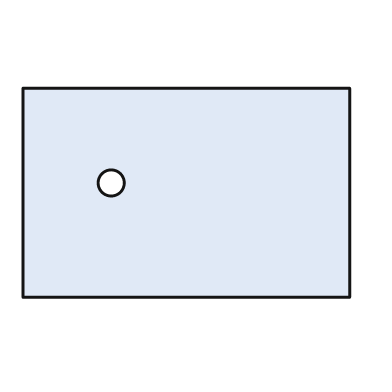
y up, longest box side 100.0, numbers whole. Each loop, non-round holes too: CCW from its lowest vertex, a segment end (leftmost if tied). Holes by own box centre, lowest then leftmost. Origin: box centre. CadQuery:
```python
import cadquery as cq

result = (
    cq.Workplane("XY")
    .moveTo(-50.0, -32.0)
    .lineTo(50.0, -32.0)
    .lineTo(50.0, 32.0)
    .lineTo(-50.0, 32.0)
    .close()
    .moveTo(-23.0, 3.0)
    .circle(4.0)
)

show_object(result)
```